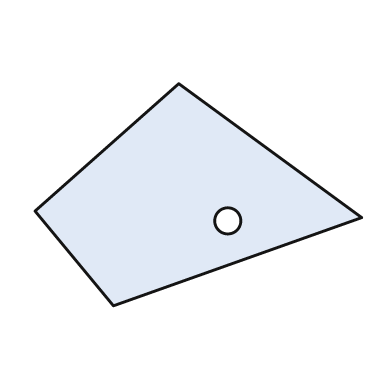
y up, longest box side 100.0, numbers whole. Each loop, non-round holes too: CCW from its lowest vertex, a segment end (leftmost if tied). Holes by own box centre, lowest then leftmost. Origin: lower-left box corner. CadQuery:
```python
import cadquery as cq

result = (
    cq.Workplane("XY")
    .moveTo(24.0, 0.0)
    .lineTo(100.0, 27.0)
    .lineTo(44.0, 68.0)
    .lineTo(0.0, 29.0)
    .close()
    .moveTo(59.0, 26.0)
    .circle(4.0)
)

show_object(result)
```